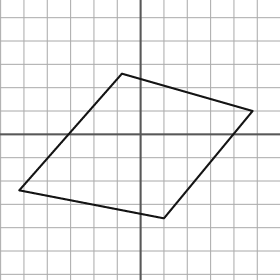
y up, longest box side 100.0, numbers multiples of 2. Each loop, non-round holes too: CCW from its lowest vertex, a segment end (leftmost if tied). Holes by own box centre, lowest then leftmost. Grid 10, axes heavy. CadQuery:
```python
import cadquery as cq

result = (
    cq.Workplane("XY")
    .moveTo(10.0, -36.0)
    .lineTo(48.0, 10.0)
    .lineTo(-8.0, 26.0)
    .lineTo(-52.0, -24.0)
    .close()
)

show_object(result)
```